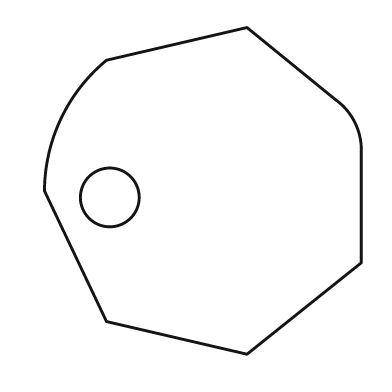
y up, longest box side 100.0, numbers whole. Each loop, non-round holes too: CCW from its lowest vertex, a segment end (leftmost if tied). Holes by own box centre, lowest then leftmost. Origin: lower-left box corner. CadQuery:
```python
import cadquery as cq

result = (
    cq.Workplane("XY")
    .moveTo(62.0, 0.0)
    .lineTo(97.0, 28.0)
    .lineTo(97.0, 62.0)
    .threePointArc((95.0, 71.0), (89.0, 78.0))
    .lineTo(62.0, 100.0)
    .lineTo(19.0, 90.0)
    .threePointArc((5.0, 72.0), (0.0, 50.0))
    .lineTo(19.0, 10.0)
    .close()
    .moveTo(20.0, 48.0)
    .circle(9.0)
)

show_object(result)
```